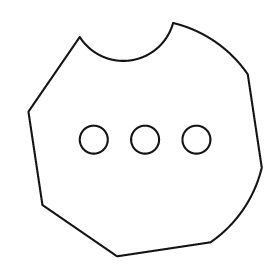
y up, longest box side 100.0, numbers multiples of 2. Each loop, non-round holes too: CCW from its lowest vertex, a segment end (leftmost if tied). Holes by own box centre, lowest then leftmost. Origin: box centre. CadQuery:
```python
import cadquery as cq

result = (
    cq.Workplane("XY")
    .moveTo(-12.0, -50.0)
    .lineTo(28.0, -44.0)
    .threePointArc((42.0, -30.0), (50.0, -12.0))
    .lineTo(44.0, 28.0)
    .threePointArc((30.0, 42.0), (12.0, 50.0))
    .threePointArc((-6.0, 34.0), (-28.0, 44.0))
    .lineTo(-50.0, 12.0)
    .lineTo(-44.0, -28.0)
    .close()
    .moveTo(-22.0, 0.0)
    .circle(6.0)
    .moveTo(0.0, 0.0)
    .circle(6.0)
    .moveTo(22.0, 0.0)
    .circle(6.0)
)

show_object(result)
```